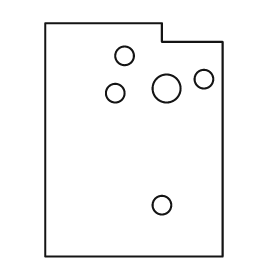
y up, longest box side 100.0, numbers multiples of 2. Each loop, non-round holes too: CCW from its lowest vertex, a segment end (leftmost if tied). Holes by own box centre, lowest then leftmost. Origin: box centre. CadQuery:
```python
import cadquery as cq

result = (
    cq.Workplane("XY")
    .moveTo(-38.0, -50.0)
    .lineTo(38.0, -50.0)
    .lineTo(38.0, 42.0)
    .lineTo(12.0, 42.0)
    .lineTo(12.0, 50.0)
    .lineTo(-38.0, 50.0)
    .close()
    .moveTo(12.0, -28.0)
    .circle(4.0)
    .moveTo(-8.0, 20.0)
    .circle(4.0)
    .moveTo(14.0, 22.0)
    .circle(6.0)
    .moveTo(30.0, 26.0)
    .circle(4.0)
    .moveTo(-4.0, 36.0)
    .circle(4.0)
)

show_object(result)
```